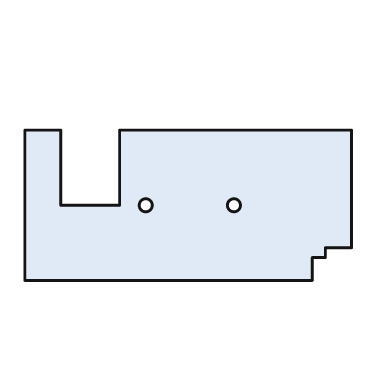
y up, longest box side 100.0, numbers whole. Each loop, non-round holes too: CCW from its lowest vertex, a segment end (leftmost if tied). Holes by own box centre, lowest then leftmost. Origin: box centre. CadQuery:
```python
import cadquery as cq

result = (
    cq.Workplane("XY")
    .moveTo(-50.0, -23.0)
    .lineTo(38.0, -23.0)
    .lineTo(38.0, -16.0)
    .lineTo(42.0, -16.0)
    .lineTo(42.0, -13.0)
    .lineTo(50.0, -13.0)
    .lineTo(50.0, 23.0)
    .lineTo(-21.0, 23.0)
    .lineTo(-21.0, 0.0)
    .lineTo(-39.0, 0.0)
    .lineTo(-39.0, 23.0)
    .lineTo(-50.0, 23.0)
    .close()
    .moveTo(-13.0, 0.0)
    .circle(2.0)
    .moveTo(14.0, 0.0)
    .circle(2.0)
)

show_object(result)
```